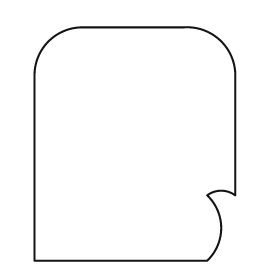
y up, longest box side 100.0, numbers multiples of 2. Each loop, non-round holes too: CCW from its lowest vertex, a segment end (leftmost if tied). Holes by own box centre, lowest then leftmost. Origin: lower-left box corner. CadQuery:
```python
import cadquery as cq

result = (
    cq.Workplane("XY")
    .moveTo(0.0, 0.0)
    .lineTo(74.0, 0.0)
    .threePointArc((80.0, 14.0), (74.0, 28.0))
    .threePointArc((80.0, 30.0), (86.0, 28.0))
    .lineTo(86.0, 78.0)
    .threePointArc((80.0, 94.0), (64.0, 100.0))
    .lineTo(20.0, 100.0)
    .threePointArc((6.0, 94.0), (0.0, 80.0))
    .close()
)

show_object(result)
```